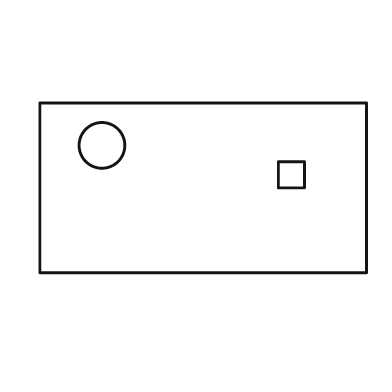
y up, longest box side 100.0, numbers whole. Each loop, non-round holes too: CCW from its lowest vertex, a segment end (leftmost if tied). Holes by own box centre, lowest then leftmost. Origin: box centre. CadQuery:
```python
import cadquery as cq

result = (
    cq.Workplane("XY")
    .moveTo(-50.0, -26.0)
    .lineTo(50.0, -26.0)
    .lineTo(50.0, 26.0)
    .lineTo(-50.0, 26.0)
    .close()
    .moveTo(23.0, 0.0)
    .lineTo(31.0, 0.0)
    .lineTo(31.0, 8.0)
    .lineTo(23.0, 8.0)
    .close()
    .moveTo(-31.0, 13.0)
    .circle(7.0)
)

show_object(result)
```